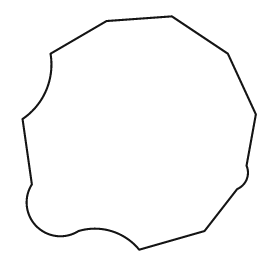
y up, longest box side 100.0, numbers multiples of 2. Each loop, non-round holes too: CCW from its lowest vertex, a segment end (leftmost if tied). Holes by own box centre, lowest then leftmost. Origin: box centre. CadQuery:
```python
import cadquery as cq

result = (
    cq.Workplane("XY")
    .moveTo(0.0, -50.0)
    .lineTo(28.0, -42.0)
    .lineTo(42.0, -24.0)
    .threePointArc((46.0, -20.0), (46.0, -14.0))
    .lineTo(50.0, 8.0)
    .lineTo(38.0, 34.0)
    .lineTo(14.0, 50.0)
    .lineTo(-14.0, 48.0)
    .lineTo(-38.0, 34.0)
    .threePointArc((-40.0, 18.0), (-50.0, 6.0))
    .lineTo(-46.0, -22.0)
    .threePointArc((-44.0, -40.0), (-26.0, -42.0))
    .threePointArc((-12.0, -42.0), (0.0, -50.0))
    .close()
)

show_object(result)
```